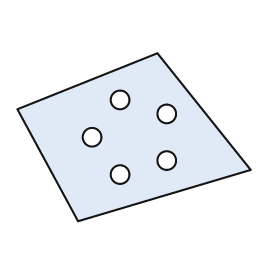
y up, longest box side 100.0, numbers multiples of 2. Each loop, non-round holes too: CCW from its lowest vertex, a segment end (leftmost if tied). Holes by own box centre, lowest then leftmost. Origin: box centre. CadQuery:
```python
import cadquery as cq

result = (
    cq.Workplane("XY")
    .moveTo(-24.0, -36.0)
    .lineTo(50.0, -14.0)
    .lineTo(10.0, 36.0)
    .lineTo(-50.0, 12.0)
    .close()
    .moveTo(-6.0, -16.0)
    .circle(4.0)
    .moveTo(14.0, -10.0)
    .circle(4.0)
    .moveTo(-18.0, 0.0)
    .circle(4.0)
    .moveTo(14.0, 10.0)
    .circle(4.0)
    .moveTo(-6.0, 16.0)
    .circle(4.0)
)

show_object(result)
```